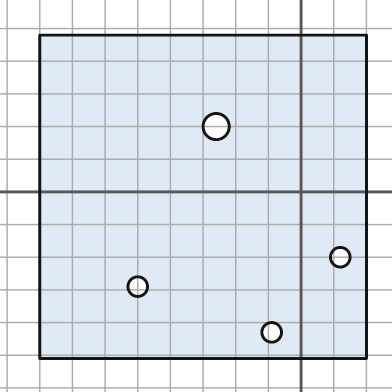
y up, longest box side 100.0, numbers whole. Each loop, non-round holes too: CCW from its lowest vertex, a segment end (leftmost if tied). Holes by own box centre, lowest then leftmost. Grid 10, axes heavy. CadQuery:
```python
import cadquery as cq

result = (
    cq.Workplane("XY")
    .moveTo(-80.0, -51.0)
    .lineTo(20.0, -51.0)
    .lineTo(20.0, 48.0)
    .lineTo(-80.0, 48.0)
    .close()
    .moveTo(-9.0, -43.0)
    .circle(3.0)
    .moveTo(-50.0, -29.0)
    .circle(3.0)
    .moveTo(12.0, -20.0)
    .circle(3.0)
    .moveTo(-26.0, 20.0)
    .circle(4.0)
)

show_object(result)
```